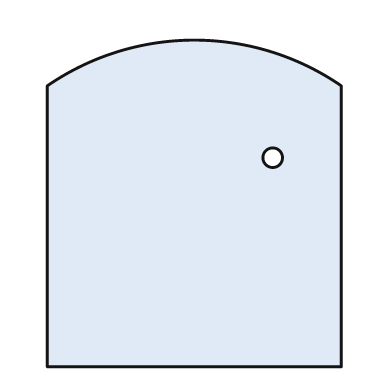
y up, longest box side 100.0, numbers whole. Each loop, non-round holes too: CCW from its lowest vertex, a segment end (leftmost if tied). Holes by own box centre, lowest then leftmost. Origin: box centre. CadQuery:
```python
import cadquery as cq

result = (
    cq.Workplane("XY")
    .moveTo(-45.0, -50.0)
    .lineTo(45.0, -50.0)
    .lineTo(45.0, 36.0)
    .threePointArc((0.0, 50.0), (-45.0, 36.0))
    .close()
    .moveTo(24.0, 14.0)
    .circle(3.0)
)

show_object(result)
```